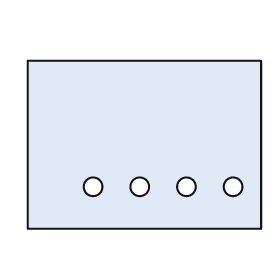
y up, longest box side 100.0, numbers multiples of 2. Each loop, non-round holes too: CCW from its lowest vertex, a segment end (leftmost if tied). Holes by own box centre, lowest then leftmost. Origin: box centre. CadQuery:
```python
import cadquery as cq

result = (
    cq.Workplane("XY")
    .moveTo(-50.0, -36.0)
    .lineTo(50.0, -36.0)
    .lineTo(50.0, 36.0)
    .lineTo(-50.0, 36.0)
    .close()
    .moveTo(-22.0, -18.0)
    .circle(4.0)
    .moveTo(-2.0, -18.0)
    .circle(4.0)
    .moveTo(18.0, -18.0)
    .circle(4.0)
    .moveTo(38.0, -18.0)
    .circle(4.0)
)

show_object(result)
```